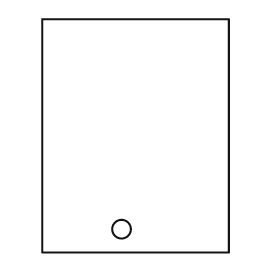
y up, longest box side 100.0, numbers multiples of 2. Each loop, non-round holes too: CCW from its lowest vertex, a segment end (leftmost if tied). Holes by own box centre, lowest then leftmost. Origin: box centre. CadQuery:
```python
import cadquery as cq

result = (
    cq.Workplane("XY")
    .moveTo(-40.0, -50.0)
    .lineTo(40.0, -50.0)
    .lineTo(40.0, 50.0)
    .lineTo(-40.0, 50.0)
    .close()
    .moveTo(-6.0, -40.0)
    .circle(4.0)
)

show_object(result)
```